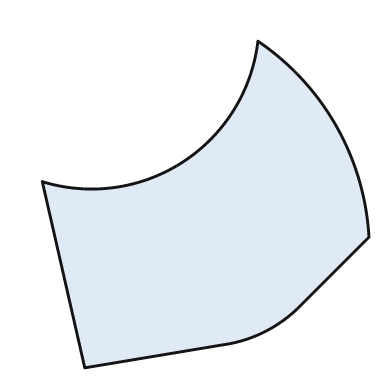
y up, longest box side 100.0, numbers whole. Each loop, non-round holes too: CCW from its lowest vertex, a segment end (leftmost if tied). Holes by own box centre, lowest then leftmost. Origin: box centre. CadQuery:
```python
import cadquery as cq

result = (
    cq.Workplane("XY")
    .moveTo(-37.0, -50.0)
    .lineTo(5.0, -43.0)
    .threePointArc((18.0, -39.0), (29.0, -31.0))
    .lineTo(50.0, -10.0)
    .threePointArc((40.0, 24.0), (16.0, 50.0))
    .threePointArc((-7.0, 13.0), (-50.0, 7.0))
    .close()
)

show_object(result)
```